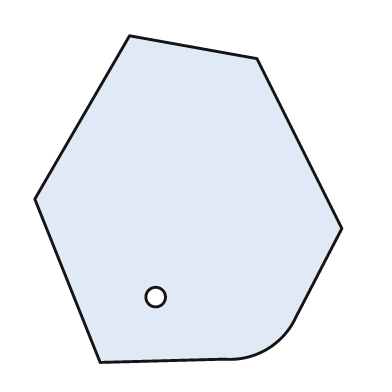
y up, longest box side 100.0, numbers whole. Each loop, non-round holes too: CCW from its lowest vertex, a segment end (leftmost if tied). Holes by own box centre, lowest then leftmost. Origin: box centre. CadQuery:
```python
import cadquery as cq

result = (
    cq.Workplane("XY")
    .moveTo(-27.0, -50.0)
    .lineTo(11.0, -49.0)
    .threePointArc((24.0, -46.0), (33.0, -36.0))
    .lineTo(47.0, -9.0)
    .lineTo(21.0, 43.0)
    .lineTo(-18.0, 50.0)
    .lineTo(-47.0, 0.0)
    .close()
    .moveTo(-10.0, -30.0)
    .circle(3.0)
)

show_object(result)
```